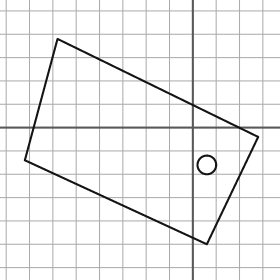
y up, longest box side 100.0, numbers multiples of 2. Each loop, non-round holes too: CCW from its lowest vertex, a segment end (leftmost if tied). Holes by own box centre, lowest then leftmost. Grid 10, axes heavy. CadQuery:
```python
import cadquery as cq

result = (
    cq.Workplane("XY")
    .moveTo(6.0, -50.0)
    .lineTo(28.0, -4.0)
    .lineTo(-58.0, 38.0)
    .lineTo(-72.0, -14.0)
    .close()
    .moveTo(6.0, -16.0)
    .circle(4.0)
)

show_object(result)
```